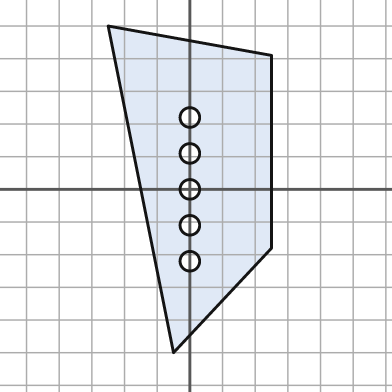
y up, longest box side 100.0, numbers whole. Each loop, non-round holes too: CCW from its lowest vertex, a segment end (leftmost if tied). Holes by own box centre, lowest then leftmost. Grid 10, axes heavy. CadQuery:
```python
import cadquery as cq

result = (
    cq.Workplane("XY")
    .moveTo(-5.0, -50.0)
    .lineTo(25.0, -18.0)
    .lineTo(25.0, 41.0)
    .lineTo(-25.0, 50.0)
    .close()
    .moveTo(0.0, -22.0)
    .circle(3.0)
    .moveTo(0.0, -11.0)
    .circle(3.0)
    .moveTo(0.0, 0.0)
    .circle(3.0)
    .moveTo(0.0, 11.0)
    .circle(3.0)
    .moveTo(0.0, 22.0)
    .circle(3.0)
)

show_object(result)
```